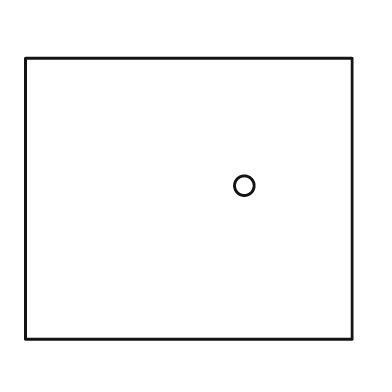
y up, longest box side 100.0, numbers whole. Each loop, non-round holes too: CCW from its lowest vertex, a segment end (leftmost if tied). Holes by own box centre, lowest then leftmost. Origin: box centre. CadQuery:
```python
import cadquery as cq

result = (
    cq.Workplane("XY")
    .moveTo(-50.0, -43.0)
    .lineTo(50.0, -43.0)
    .lineTo(50.0, 43.0)
    .lineTo(-50.0, 43.0)
    .close()
    .moveTo(17.0, 4.0)
    .circle(3.0)
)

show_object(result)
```